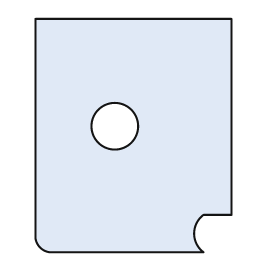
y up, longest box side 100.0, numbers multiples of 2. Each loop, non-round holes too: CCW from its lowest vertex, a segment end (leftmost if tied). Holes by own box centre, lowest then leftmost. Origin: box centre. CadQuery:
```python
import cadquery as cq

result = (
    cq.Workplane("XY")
    .moveTo(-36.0, -50.0)
    .lineTo(30.0, -50.0)
    .threePointArc((26.0, -42.0), (30.0, -34.0))
    .lineTo(42.0, -34.0)
    .lineTo(42.0, 50.0)
    .lineTo(-42.0, 50.0)
    .lineTo(-42.0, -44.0)
    .threePointArc((-40.0, -48.0), (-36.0, -50.0))
    .close()
    .moveTo(-8.0, 4.0)
    .circle(10.0)
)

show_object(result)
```